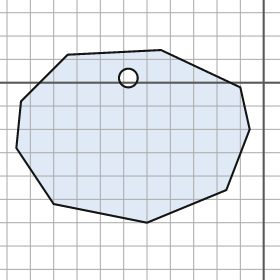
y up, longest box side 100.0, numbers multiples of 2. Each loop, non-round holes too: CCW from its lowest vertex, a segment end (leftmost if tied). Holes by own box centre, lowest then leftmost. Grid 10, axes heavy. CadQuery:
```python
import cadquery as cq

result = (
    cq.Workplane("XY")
    .moveTo(-50.0, -60.0)
    .lineTo(-16.0, -46.0)
    .lineTo(-6.0, -20.0)
    .lineTo(-10.0, -2.0)
    .lineTo(-44.0, 14.0)
    .lineTo(-84.0, 12.0)
    .lineTo(-104.0, -8.0)
    .lineTo(-106.0, -28.0)
    .lineTo(-90.0, -52.0)
    .close()
    .moveTo(-58.0, 2.0)
    .circle(4.0)
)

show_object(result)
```